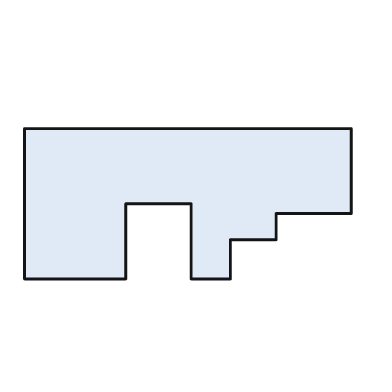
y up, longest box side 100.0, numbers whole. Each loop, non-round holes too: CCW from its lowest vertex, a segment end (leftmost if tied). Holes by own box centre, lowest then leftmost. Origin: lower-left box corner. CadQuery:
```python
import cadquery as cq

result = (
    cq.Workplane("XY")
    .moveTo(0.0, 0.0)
    .lineTo(31.0, 0.0)
    .lineTo(31.0, 23.0)
    .lineTo(51.0, 23.0)
    .lineTo(51.0, 0.0)
    .lineTo(63.0, 0.0)
    .lineTo(63.0, 12.0)
    .lineTo(77.0, 12.0)
    .lineTo(77.0, 20.0)
    .lineTo(100.0, 20.0)
    .lineTo(100.0, 46.0)
    .lineTo(0.0, 46.0)
    .close()
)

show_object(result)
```